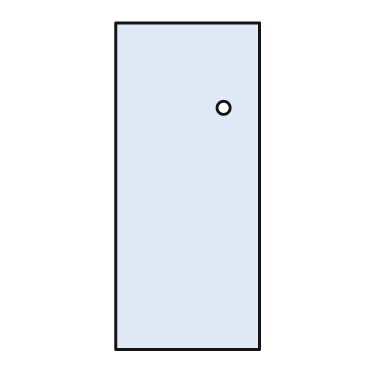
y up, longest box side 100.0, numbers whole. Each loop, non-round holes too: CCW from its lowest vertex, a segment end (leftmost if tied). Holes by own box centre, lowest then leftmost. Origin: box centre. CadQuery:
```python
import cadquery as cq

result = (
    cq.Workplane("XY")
    .moveTo(-22.0, -50.0)
    .lineTo(22.0, -50.0)
    .lineTo(22.0, 50.0)
    .lineTo(-22.0, 50.0)
    .close()
    .moveTo(11.0, 24.0)
    .circle(2.0)
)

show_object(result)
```